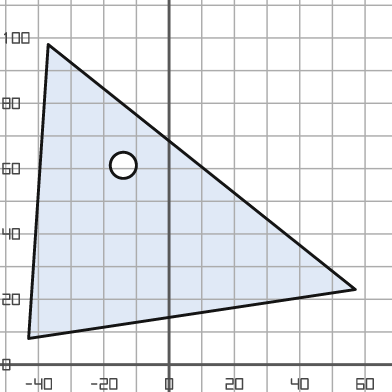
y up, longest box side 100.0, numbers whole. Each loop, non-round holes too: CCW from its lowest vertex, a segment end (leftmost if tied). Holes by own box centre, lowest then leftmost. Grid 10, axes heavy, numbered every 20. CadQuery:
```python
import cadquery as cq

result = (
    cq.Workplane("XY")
    .moveTo(-43.0, 8.0)
    .lineTo(57.0, 23.0)
    .lineTo(-37.0, 98.0)
    .close()
    .moveTo(-14.0, 61.0)
    .circle(4.0)
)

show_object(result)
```